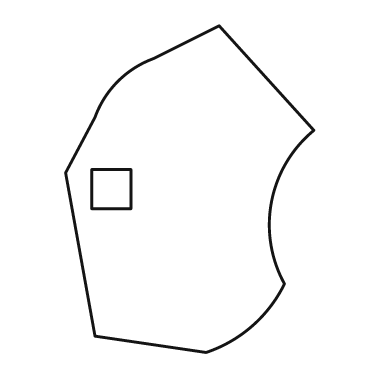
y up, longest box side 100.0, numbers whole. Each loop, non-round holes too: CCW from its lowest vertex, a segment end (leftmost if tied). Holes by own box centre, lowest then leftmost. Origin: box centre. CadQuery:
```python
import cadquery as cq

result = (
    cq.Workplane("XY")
    .moveTo(5.0, -50.0)
    .threePointArc((19.0, -42.0), (29.0, -29.0))
    .threePointArc((25.0, -4.0), (38.0, 18.0))
    .lineTo(9.0, 50.0)
    .lineTo(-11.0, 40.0)
    .threePointArc((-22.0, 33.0), (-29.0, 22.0))
    .lineTo(-38.0, 5.0)
    .lineTo(-29.0, -45.0)
    .close()
    .moveTo(-30.0, -6.0)
    .lineTo(-18.0, -6.0)
    .lineTo(-18.0, 6.0)
    .lineTo(-30.0, 6.0)
    .close()
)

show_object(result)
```